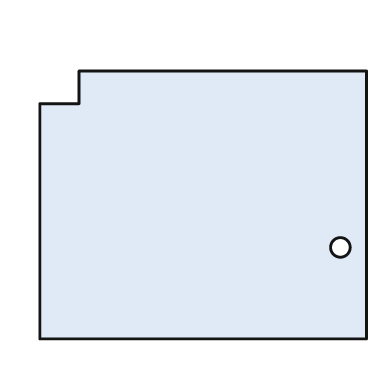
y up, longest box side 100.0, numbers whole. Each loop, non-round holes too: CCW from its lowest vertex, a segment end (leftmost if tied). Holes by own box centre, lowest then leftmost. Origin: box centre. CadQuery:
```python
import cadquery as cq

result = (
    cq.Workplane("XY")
    .moveTo(-50.0, -41.0)
    .lineTo(50.0, -41.0)
    .lineTo(50.0, 41.0)
    .lineTo(-38.0, 41.0)
    .lineTo(-38.0, 31.0)
    .lineTo(-50.0, 31.0)
    .close()
    .moveTo(42.0, -13.0)
    .circle(3.0)
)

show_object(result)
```